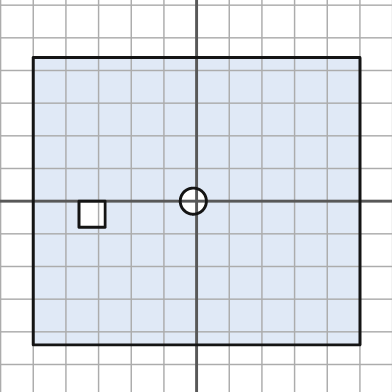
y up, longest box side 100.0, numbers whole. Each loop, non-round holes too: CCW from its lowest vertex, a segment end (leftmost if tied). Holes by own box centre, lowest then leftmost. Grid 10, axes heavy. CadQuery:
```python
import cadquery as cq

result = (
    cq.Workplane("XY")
    .moveTo(-50.0, -44.0)
    .lineTo(50.0, -44.0)
    .lineTo(50.0, 44.0)
    .lineTo(-50.0, 44.0)
    .close()
    .moveTo(-36.0, -8.0)
    .lineTo(-28.0, -8.0)
    .lineTo(-28.0, 0.0)
    .lineTo(-36.0, 0.0)
    .close()
    .moveTo(-1.0, 0.0)
    .circle(4.0)
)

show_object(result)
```